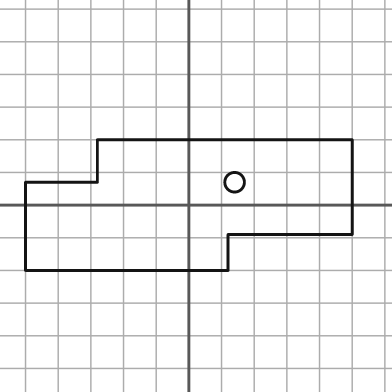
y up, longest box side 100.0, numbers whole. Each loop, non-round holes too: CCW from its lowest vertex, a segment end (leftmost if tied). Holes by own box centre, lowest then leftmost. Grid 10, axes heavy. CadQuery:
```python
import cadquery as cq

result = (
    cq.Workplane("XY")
    .moveTo(-50.0, -20.0)
    .lineTo(12.0, -20.0)
    .lineTo(12.0, -9.0)
    .lineTo(50.0, -9.0)
    .lineTo(50.0, 20.0)
    .lineTo(-28.0, 20.0)
    .lineTo(-28.0, 7.0)
    .lineTo(-50.0, 7.0)
    .close()
    .moveTo(14.0, 7.0)
    .circle(3.0)
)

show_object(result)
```